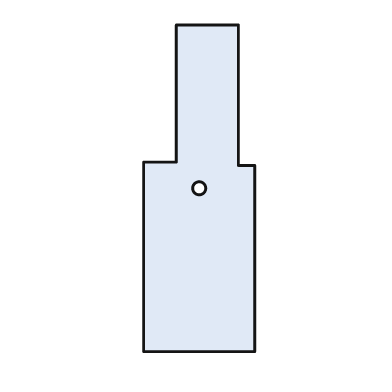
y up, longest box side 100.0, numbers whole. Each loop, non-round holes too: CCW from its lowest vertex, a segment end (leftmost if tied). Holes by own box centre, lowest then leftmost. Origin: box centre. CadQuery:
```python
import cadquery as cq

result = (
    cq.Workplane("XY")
    .moveTo(-17.0, -50.0)
    .lineTo(17.0, -50.0)
    .lineTo(17.0, 7.0)
    .lineTo(12.0, 7.0)
    .lineTo(12.0, 50.0)
    .lineTo(-7.0, 50.0)
    .lineTo(-7.0, 8.0)
    .lineTo(-17.0, 8.0)
    .close()
    .moveTo(0.0, 0.0)
    .circle(2.0)
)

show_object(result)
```